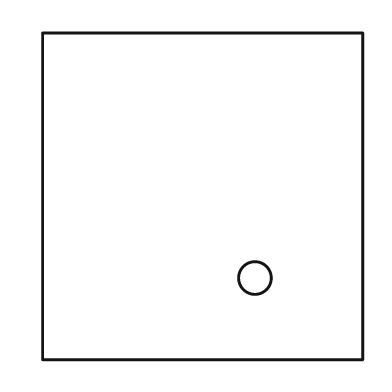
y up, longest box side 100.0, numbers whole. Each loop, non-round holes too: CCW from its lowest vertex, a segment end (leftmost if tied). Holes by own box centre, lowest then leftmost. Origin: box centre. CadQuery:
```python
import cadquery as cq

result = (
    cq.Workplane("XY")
    .moveTo(-49.0, -50.0)
    .lineTo(49.0, -50.0)
    .lineTo(49.0, 50.0)
    .lineTo(-49.0, 50.0)
    .close()
    .moveTo(16.0, -25.0)
    .circle(5.0)
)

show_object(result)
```